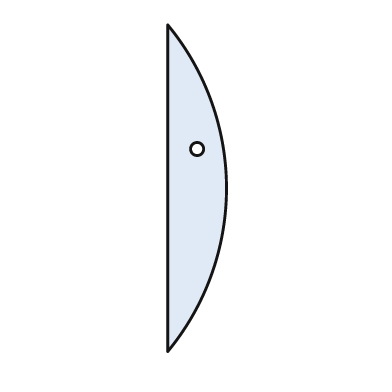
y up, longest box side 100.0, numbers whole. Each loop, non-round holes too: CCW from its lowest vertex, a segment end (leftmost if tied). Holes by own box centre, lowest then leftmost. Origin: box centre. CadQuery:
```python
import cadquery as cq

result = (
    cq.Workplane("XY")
    .moveTo(-9.0, -50.0)
    .threePointArc((9.0, 0.0), (-9.0, 50.0))
    .close()
    .moveTo(0.0, 12.0)
    .circle(2.0)
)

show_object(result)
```